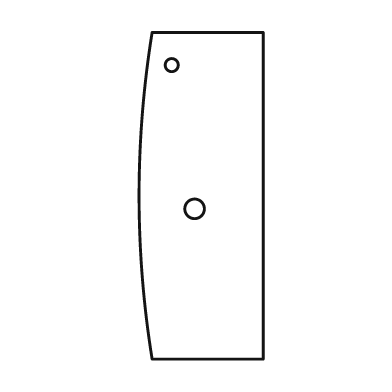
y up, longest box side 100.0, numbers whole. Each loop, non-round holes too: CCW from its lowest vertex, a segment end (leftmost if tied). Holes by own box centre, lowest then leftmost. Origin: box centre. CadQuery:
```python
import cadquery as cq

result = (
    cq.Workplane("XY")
    .moveTo(-15.0, -50.0)
    .lineTo(19.0, -50.0)
    .lineTo(19.0, 50.0)
    .lineTo(-15.0, 50.0)
    .threePointArc((-19.0, 0.0), (-15.0, -50.0))
    .close()
    .moveTo(-2.0, -4.0)
    .circle(3.0)
    .moveTo(-9.0, 40.0)
    .circle(2.0)
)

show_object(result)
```